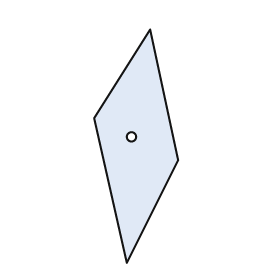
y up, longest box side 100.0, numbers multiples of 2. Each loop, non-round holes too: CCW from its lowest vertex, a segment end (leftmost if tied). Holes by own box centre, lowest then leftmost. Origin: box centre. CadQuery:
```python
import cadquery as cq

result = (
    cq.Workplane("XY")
    .moveTo(-4.0, -50.0)
    .lineTo(18.0, -6.0)
    .lineTo(6.0, 50.0)
    .lineTo(-18.0, 12.0)
    .close()
    .moveTo(-2.0, 4.0)
    .circle(2.0)
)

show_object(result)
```